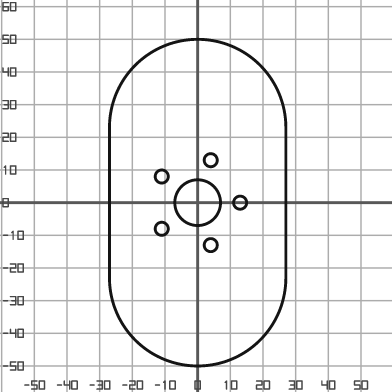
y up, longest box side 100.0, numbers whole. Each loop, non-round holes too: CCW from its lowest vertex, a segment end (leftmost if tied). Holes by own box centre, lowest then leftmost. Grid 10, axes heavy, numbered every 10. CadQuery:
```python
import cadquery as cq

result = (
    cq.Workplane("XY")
    .moveTo(-27.0, -23.0)
    .threePointArc((0.0, -50.0), (27.0, -23.0))
    .lineTo(27.0, 23.0)
    .threePointArc((0.0, 50.0), (-27.0, 23.0))
    .close()
    .moveTo(4.0, -13.0)
    .circle(2.0)
    .moveTo(-11.0, -8.0)
    .circle(2.0)
    .moveTo(0.0, 0.0)
    .circle(7.0)
    .moveTo(13.0, 0.0)
    .circle(2.0)
    .moveTo(-11.0, 8.0)
    .circle(2.0)
    .moveTo(4.0, 13.0)
    .circle(2.0)
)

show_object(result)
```